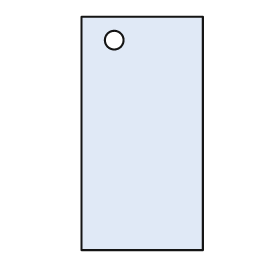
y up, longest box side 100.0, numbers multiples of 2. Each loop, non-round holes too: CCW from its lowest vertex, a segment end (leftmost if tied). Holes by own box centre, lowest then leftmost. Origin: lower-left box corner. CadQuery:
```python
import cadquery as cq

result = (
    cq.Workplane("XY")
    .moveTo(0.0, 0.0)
    .lineTo(52.0, 0.0)
    .lineTo(52.0, 100.0)
    .lineTo(0.0, 100.0)
    .close()
    .moveTo(14.0, 90.0)
    .circle(4.0)
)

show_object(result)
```